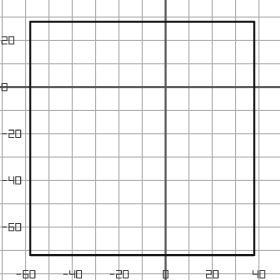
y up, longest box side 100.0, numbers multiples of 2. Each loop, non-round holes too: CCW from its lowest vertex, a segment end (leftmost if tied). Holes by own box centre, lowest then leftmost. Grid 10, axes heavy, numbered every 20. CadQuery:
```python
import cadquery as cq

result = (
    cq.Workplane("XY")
    .moveTo(-58.0, -72.0)
    .lineTo(38.0, -72.0)
    .lineTo(38.0, 28.0)
    .lineTo(-58.0, 28.0)
    .close()
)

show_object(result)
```